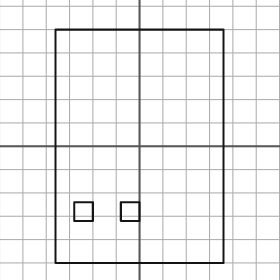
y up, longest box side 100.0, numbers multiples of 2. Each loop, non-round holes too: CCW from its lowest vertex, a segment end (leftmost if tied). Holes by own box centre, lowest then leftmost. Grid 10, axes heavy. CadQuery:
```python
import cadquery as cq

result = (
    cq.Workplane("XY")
    .moveTo(-36.0, -50.0)
    .lineTo(36.0, -50.0)
    .lineTo(36.0, 50.0)
    .lineTo(-36.0, 50.0)
    .close()
    .moveTo(-28.0, -32.0)
    .lineTo(-20.0, -32.0)
    .lineTo(-20.0, -24.0)
    .lineTo(-28.0, -24.0)
    .close()
    .moveTo(-8.0, -32.0)
    .lineTo(0.0, -32.0)
    .lineTo(0.0, -24.0)
    .lineTo(-8.0, -24.0)
    .close()
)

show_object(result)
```